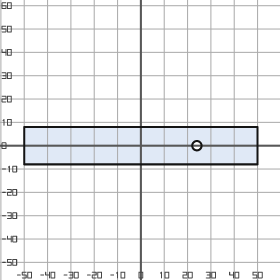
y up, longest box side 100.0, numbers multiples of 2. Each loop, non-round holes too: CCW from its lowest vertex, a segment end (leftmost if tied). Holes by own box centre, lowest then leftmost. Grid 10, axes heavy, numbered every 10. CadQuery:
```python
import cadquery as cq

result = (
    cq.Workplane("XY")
    .moveTo(-50.0, -8.0)
    .lineTo(50.0, -8.0)
    .lineTo(50.0, 8.0)
    .lineTo(-50.0, 8.0)
    .close()
    .moveTo(24.0, 0.0)
    .circle(2.0)
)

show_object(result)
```